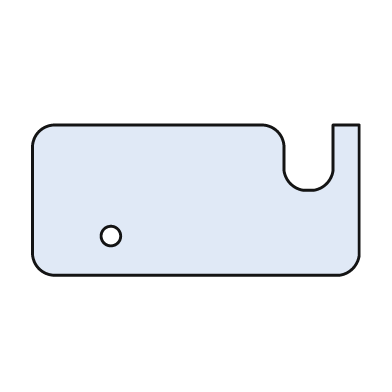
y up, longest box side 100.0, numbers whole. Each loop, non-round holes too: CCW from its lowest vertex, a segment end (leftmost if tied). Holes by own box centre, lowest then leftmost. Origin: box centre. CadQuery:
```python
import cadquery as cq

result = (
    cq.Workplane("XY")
    .moveTo(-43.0, -23.0)
    .lineTo(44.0, -23.0)
    .threePointArc((48.0, -21.0), (50.0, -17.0))
    .lineTo(50.0, 23.0)
    .lineTo(42.0, 23.0)
    .lineTo(42.0, 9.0)
    .threePointArc((40.0, 5.0), (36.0, 3.0))
    .lineTo(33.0, 3.0)
    .threePointArc((29.0, 5.0), (27.0, 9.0))
    .lineTo(27.0, 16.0)
    .threePointArc((25.0, 21.0), (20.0, 23.0))
    .lineTo(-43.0, 23.0)
    .threePointArc((-48.0, 21.0), (-50.0, 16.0))
    .lineTo(-50.0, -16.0)
    .threePointArc((-48.0, -21.0), (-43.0, -23.0))
    .close()
    .moveTo(-26.0, -11.0)
    .circle(3.0)
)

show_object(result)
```